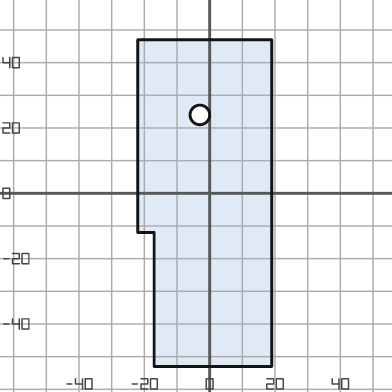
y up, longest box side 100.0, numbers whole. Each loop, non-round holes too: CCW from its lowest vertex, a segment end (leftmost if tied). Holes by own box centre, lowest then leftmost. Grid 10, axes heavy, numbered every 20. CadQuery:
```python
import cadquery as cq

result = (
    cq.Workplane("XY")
    .moveTo(-17.0, -53.0)
    .lineTo(19.0, -53.0)
    .lineTo(19.0, 47.0)
    .lineTo(-22.0, 47.0)
    .lineTo(-22.0, -12.0)
    .lineTo(-17.0, -12.0)
    .close()
    .moveTo(-3.0, 24.0)
    .circle(3.0)
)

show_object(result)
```